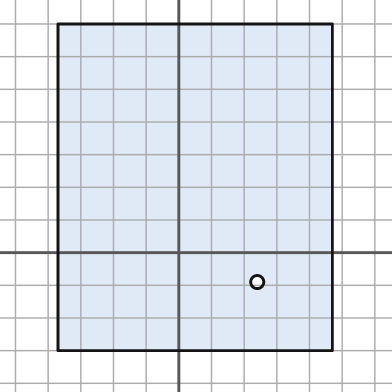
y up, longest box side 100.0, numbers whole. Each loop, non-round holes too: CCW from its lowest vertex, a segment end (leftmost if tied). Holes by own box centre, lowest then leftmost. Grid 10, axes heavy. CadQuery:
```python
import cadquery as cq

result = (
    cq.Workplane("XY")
    .moveTo(-37.0, -30.0)
    .lineTo(47.0, -30.0)
    .lineTo(47.0, 70.0)
    .lineTo(-37.0, 70.0)
    .close()
    .moveTo(24.0, -9.0)
    .circle(2.0)
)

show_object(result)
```